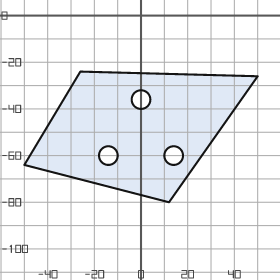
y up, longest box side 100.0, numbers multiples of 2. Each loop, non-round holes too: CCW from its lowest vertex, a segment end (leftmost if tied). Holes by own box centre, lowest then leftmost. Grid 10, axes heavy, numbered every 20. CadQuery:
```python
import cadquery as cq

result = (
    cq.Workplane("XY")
    .moveTo(12.0, -80.0)
    .lineTo(50.0, -26.0)
    .lineTo(-26.0, -24.0)
    .lineTo(-50.0, -64.0)
    .close()
    .moveTo(-14.0, -60.0)
    .circle(4.0)
    .moveTo(14.0, -60.0)
    .circle(4.0)
    .moveTo(0.0, -36.0)
    .circle(4.0)
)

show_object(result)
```